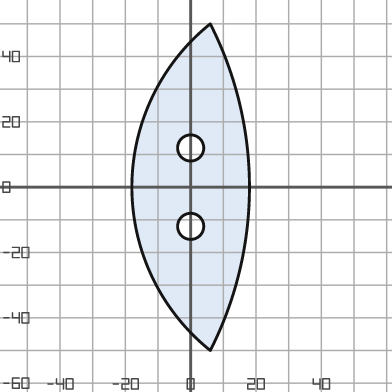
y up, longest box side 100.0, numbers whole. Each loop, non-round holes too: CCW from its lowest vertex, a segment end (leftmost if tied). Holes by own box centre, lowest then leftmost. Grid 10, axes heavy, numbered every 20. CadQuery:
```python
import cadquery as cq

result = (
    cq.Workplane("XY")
    .moveTo(6.0, -50.0)
    .threePointArc((18.0, 0.0), (6.0, 50.0))
    .threePointArc((-18.0, 0.0), (6.0, -50.0))
    .close()
    .moveTo(0.0, -12.0)
    .circle(4.0)
    .moveTo(0.0, 12.0)
    .circle(4.0)
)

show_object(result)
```